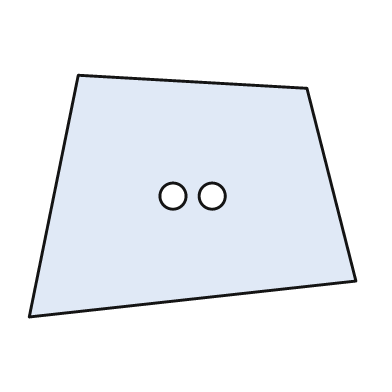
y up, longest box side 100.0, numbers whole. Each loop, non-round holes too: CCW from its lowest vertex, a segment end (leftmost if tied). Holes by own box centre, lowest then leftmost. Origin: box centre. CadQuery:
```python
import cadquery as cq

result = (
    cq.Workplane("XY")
    .moveTo(-50.0, -37.0)
    .lineTo(50.0, -26.0)
    .lineTo(35.0, 33.0)
    .lineTo(-35.0, 37.0)
    .close()
    .moveTo(-6.0, 0.0)
    .circle(4.0)
    .moveTo(6.0, 0.0)
    .circle(4.0)
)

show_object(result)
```